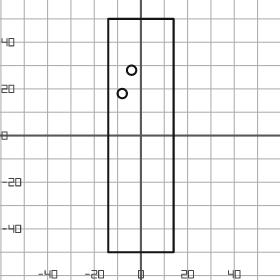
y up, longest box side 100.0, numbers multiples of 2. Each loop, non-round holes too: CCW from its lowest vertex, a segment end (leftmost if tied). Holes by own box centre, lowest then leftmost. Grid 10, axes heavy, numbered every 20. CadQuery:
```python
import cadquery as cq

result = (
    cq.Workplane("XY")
    .moveTo(-14.0, -50.0)
    .lineTo(14.0, -50.0)
    .lineTo(14.0, 50.0)
    .lineTo(-14.0, 50.0)
    .close()
    .moveTo(-8.0, 18.0)
    .circle(2.0)
    .moveTo(-4.0, 28.0)
    .circle(2.0)
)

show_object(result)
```